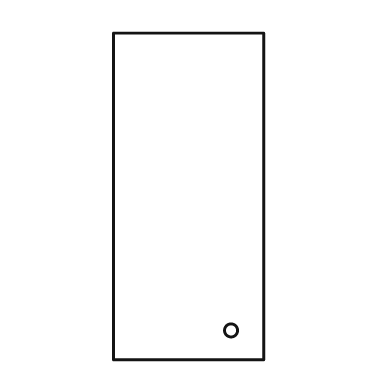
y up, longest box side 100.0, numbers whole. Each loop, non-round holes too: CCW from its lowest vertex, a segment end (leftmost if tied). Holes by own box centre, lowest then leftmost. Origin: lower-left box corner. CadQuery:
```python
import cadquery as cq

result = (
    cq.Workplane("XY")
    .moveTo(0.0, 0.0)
    .lineTo(46.0, 0.0)
    .lineTo(46.0, 100.0)
    .lineTo(0.0, 100.0)
    .close()
    .moveTo(36.0, 9.0)
    .circle(2.0)
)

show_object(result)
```